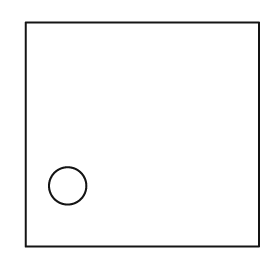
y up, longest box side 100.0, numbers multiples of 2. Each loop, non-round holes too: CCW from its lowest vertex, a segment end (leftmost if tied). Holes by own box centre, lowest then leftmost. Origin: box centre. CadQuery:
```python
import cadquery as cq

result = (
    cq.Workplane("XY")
    .moveTo(-50.0, -48.0)
    .lineTo(50.0, -48.0)
    .lineTo(50.0, 48.0)
    .lineTo(-50.0, 48.0)
    .close()
    .moveTo(-32.0, -22.0)
    .circle(8.0)
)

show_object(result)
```